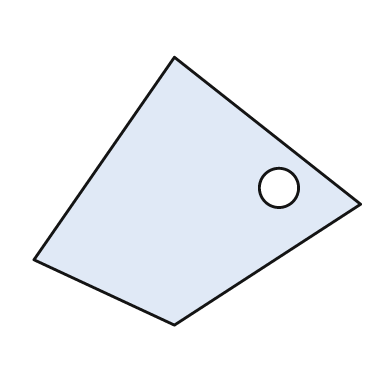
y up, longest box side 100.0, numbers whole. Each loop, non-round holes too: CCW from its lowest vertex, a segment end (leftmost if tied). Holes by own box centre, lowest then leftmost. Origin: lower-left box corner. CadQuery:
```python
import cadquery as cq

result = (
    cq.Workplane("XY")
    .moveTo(43.0, 0.0)
    .lineTo(100.0, 37.0)
    .lineTo(43.0, 82.0)
    .lineTo(0.0, 20.0)
    .close()
    .moveTo(75.0, 42.0)
    .circle(6.0)
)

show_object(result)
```